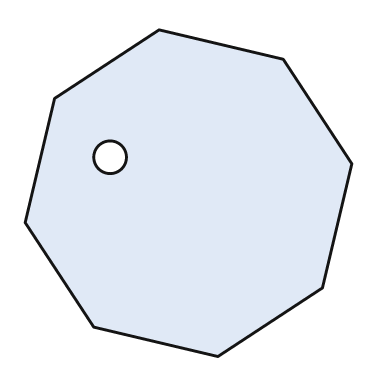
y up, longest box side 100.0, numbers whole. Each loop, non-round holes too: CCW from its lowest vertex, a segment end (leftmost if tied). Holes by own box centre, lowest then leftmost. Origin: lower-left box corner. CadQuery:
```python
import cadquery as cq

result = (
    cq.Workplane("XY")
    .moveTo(59.0, 0.0)
    .lineTo(91.0, 21.0)
    .lineTo(100.0, 59.0)
    .lineTo(79.0, 91.0)
    .lineTo(41.0, 100.0)
    .lineTo(9.0, 79.0)
    .lineTo(0.0, 41.0)
    .lineTo(21.0, 9.0)
    .close()
    .moveTo(26.0, 61.0)
    .circle(5.0)
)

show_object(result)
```